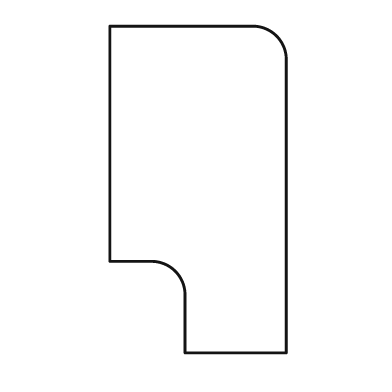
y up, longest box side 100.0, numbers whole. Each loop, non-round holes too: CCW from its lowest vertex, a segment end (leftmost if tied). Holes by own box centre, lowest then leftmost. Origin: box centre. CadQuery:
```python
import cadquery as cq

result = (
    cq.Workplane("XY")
    .moveTo(-4.0, -50.0)
    .lineTo(27.0, -50.0)
    .lineTo(27.0, 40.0)
    .threePointArc((24.0, 47.0), (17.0, 50.0))
    .lineTo(-27.0, 50.0)
    .lineTo(-27.0, -22.0)
    .lineTo(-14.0, -22.0)
    .threePointArc((-7.0, -25.0), (-4.0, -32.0))
    .close()
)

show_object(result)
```